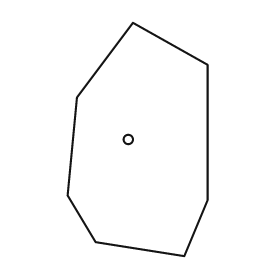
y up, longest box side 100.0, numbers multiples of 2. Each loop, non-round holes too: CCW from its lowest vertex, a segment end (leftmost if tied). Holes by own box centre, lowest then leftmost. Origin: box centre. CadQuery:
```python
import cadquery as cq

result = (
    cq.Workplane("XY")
    .moveTo(20.0, -50.0)
    .lineTo(30.0, -26.0)
    .lineTo(30.0, 32.0)
    .lineTo(-2.0, 50.0)
    .lineTo(-26.0, 18.0)
    .lineTo(-30.0, -24.0)
    .lineTo(-18.0, -44.0)
    .close()
    .moveTo(-4.0, 0.0)
    .circle(2.0)
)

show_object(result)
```